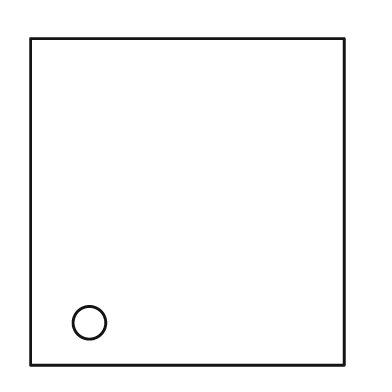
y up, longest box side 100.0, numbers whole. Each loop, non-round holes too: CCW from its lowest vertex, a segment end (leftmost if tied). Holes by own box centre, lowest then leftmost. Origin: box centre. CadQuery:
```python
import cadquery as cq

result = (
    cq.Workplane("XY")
    .moveTo(-48.0, -50.0)
    .lineTo(48.0, -50.0)
    .lineTo(48.0, 50.0)
    .lineTo(-48.0, 50.0)
    .close()
    .moveTo(-30.0, -37.0)
    .circle(5.0)
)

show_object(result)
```